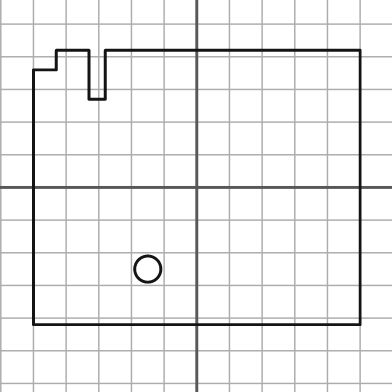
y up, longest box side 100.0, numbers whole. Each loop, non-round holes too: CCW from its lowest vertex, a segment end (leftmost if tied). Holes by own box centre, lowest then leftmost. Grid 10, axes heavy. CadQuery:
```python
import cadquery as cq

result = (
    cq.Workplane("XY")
    .moveTo(-50.0, -42.0)
    .lineTo(50.0, -42.0)
    .lineTo(50.0, 42.0)
    .lineTo(-28.0, 42.0)
    .lineTo(-28.0, 27.0)
    .lineTo(-33.0, 27.0)
    .lineTo(-33.0, 42.0)
    .lineTo(-43.0, 42.0)
    .lineTo(-43.0, 36.0)
    .lineTo(-50.0, 36.0)
    .close()
    .moveTo(-15.0, -25.0)
    .circle(4.0)
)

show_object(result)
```